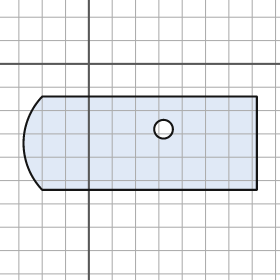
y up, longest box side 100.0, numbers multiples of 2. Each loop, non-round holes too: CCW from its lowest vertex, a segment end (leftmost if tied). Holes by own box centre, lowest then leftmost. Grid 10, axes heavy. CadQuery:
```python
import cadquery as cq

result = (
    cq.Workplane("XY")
    .moveTo(-20.0, -54.0)
    .lineTo(72.0, -54.0)
    .lineTo(72.0, -14.0)
    .lineTo(-20.0, -14.0)
    .threePointArc((-28.0, -34.0), (-20.0, -54.0))
    .close()
    .moveTo(32.0, -28.0)
    .circle(4.0)
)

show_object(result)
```